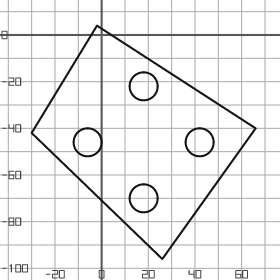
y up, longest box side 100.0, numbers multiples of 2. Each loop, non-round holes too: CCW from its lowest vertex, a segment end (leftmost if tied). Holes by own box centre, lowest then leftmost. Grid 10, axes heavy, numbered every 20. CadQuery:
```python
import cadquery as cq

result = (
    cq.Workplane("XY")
    .moveTo(26.0, -96.0)
    .lineTo(66.0, -40.0)
    .lineTo(-2.0, 4.0)
    .lineTo(-30.0, -42.0)
    .close()
    .moveTo(18.0, -70.0)
    .circle(6.0)
    .moveTo(-6.0, -46.0)
    .circle(6.0)
    .moveTo(42.0, -46.0)
    .circle(6.0)
    .moveTo(18.0, -22.0)
    .circle(6.0)
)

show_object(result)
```